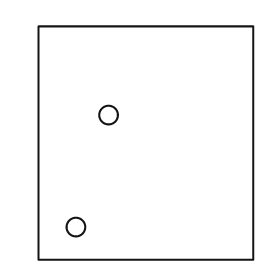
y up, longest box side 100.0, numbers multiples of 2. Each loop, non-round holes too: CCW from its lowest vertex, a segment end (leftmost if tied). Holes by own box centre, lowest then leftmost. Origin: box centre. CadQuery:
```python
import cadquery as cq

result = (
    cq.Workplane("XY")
    .moveTo(-46.0, -50.0)
    .lineTo(46.0, -50.0)
    .lineTo(46.0, 50.0)
    .lineTo(-46.0, 50.0)
    .close()
    .moveTo(-30.0, -36.0)
    .circle(4.0)
    .moveTo(-16.0, 12.0)
    .circle(4.0)
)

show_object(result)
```